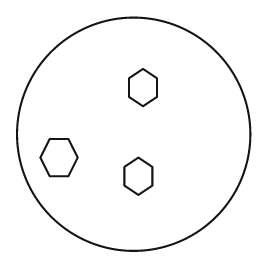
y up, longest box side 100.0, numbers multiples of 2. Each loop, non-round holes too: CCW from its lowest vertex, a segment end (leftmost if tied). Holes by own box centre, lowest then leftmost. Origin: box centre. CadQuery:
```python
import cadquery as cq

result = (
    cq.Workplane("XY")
    .moveTo(0.0, 0.0)
    .circle(50.0)
    .moveTo(2.0, -26.0)
    .lineTo(8.0, -22.0)
    .lineTo(8.0, -14.0)
    .lineTo(2.0, -10.0)
    .lineTo(-4.0, -14.0)
    .lineTo(-4.0, -22.0)
    .close()
    .moveTo(-36.0, -18.0)
    .lineTo(-28.0, -18.0)
    .lineTo(-24.0, -10.0)
    .lineTo(-28.0, -2.0)
    .lineTo(-36.0, -2.0)
    .lineTo(-40.0, -10.0)
    .close()
    .moveTo(4.0, 12.0)
    .lineTo(10.0, 16.0)
    .lineTo(10.0, 24.0)
    .lineTo(4.0, 28.0)
    .lineTo(-2.0, 24.0)
    .lineTo(-2.0, 16.0)
    .close()
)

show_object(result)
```